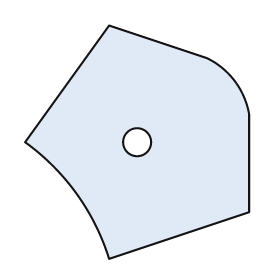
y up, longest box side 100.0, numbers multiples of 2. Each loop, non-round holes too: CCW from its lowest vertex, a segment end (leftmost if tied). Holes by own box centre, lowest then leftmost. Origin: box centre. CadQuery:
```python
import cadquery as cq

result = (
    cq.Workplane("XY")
    .moveTo(-12.0, -50.0)
    .lineTo(48.0, -30.0)
    .lineTo(48.0, 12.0)
    .threePointArc((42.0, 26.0), (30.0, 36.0))
    .lineTo(-12.0, 50.0)
    .lineTo(-48.0, 0.0)
    .threePointArc((-26.0, -22.0), (-12.0, -50.0))
    .close()
    .moveTo(0.0, 0.0)
    .circle(6.0)
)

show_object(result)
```